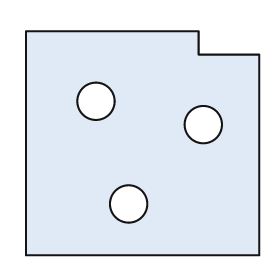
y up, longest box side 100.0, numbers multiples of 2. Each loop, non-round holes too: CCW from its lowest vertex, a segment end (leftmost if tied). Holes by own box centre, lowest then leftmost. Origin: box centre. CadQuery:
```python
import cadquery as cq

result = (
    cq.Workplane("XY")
    .moveTo(-50.0, -48.0)
    .lineTo(50.0, -48.0)
    .lineTo(50.0, 38.0)
    .lineTo(24.0, 38.0)
    .lineTo(24.0, 48.0)
    .lineTo(-50.0, 48.0)
    .close()
    .moveTo(-6.0, -26.0)
    .circle(8.0)
    .moveTo(26.0, 8.0)
    .circle(8.0)
    .moveTo(-20.0, 18.0)
    .circle(8.0)
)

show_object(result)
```